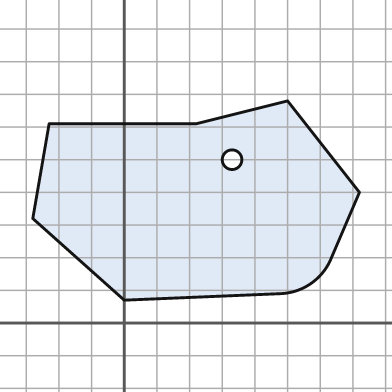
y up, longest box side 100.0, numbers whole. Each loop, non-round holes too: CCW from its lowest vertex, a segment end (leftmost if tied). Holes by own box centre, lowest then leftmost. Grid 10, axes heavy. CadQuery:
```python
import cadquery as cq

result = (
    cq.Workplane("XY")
    .moveTo(0.0, 7.0)
    .lineTo(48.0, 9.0)
    .threePointArc((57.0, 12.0), (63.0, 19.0))
    .lineTo(72.0, 40.0)
    .lineTo(50.0, 68.0)
    .lineTo(22.0, 61.0)
    .lineTo(-23.0, 61.0)
    .lineTo(-28.0, 32.0)
    .close()
    .moveTo(33.0, 50.0)
    .circle(3.0)
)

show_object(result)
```